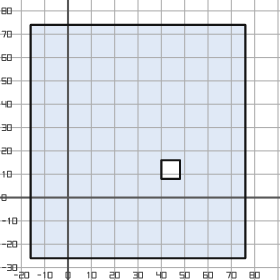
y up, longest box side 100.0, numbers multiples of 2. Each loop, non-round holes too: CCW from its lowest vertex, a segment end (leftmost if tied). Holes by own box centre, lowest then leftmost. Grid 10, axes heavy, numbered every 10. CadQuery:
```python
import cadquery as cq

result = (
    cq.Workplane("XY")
    .moveTo(-16.0, -26.0)
    .lineTo(76.0, -26.0)
    .lineTo(76.0, 74.0)
    .lineTo(-16.0, 74.0)
    .close()
    .moveTo(40.0, 8.0)
    .lineTo(48.0, 8.0)
    .lineTo(48.0, 16.0)
    .lineTo(40.0, 16.0)
    .close()
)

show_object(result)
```